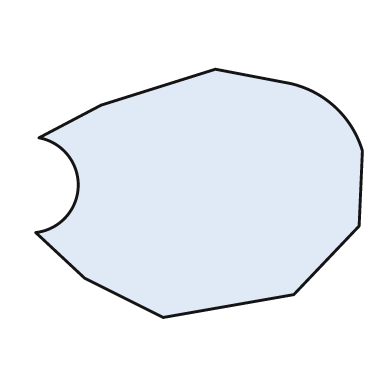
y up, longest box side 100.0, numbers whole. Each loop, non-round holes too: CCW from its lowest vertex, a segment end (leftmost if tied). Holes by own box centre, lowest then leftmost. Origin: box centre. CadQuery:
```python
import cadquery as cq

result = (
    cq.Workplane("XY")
    .moveTo(-11.0, -38.0)
    .lineTo(29.0, -31.0)
    .lineTo(49.0, -10.0)
    .lineTo(50.0, 13.0)
    .threePointArc((41.0, 27.0), (26.0, 34.0))
    .lineTo(5.0, 38.0)
    .lineTo(-30.0, 27.0)
    .lineTo(-49.0, 17.0)
    .threePointArc((-37.0, 2.0), (-50.0, -12.0))
    .lineTo(-35.0, -26.0)
    .close()
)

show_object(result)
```